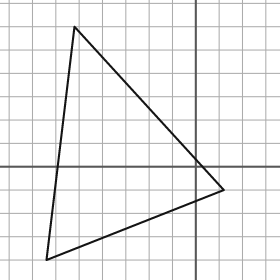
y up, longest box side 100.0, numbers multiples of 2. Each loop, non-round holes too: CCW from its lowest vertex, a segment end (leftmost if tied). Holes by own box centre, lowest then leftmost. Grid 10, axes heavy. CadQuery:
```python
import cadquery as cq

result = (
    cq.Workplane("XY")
    .moveTo(-64.0, -40.0)
    .lineTo(12.0, -10.0)
    .lineTo(-52.0, 60.0)
    .close()
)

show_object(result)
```